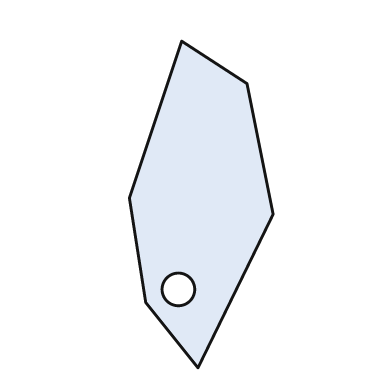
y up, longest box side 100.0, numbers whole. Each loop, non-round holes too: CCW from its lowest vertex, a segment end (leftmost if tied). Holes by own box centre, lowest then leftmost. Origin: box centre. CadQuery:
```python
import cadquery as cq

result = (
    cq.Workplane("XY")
    .moveTo(-1.0, -50.0)
    .lineTo(22.0, -3.0)
    .lineTo(14.0, 37.0)
    .lineTo(-6.0, 50.0)
    .lineTo(-22.0, 2.0)
    .lineTo(-17.0, -30.0)
    .close()
    .moveTo(-7.0, -26.0)
    .circle(5.0)
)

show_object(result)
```